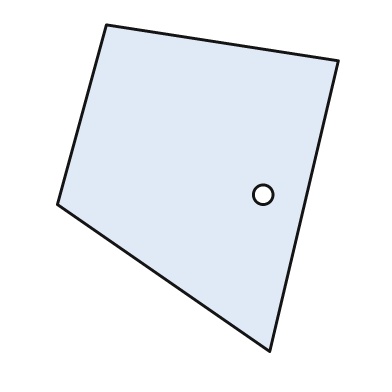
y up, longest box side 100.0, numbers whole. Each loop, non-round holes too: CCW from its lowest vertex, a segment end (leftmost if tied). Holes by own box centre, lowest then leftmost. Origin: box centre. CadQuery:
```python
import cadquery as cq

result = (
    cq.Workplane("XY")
    .moveTo(22.0, -50.0)
    .lineTo(43.0, 39.0)
    .lineTo(-28.0, 50.0)
    .lineTo(-43.0, -5.0)
    .close()
    .moveTo(20.0, -2.0)
    .circle(3.0)
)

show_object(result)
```